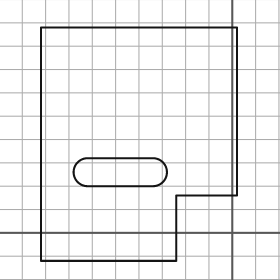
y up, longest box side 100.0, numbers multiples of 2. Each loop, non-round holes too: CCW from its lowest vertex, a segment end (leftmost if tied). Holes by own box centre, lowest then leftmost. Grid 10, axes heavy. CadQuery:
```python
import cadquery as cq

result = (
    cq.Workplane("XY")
    .moveTo(-82.0, -12.0)
    .lineTo(-24.0, -12.0)
    .lineTo(-24.0, 16.0)
    .lineTo(2.0, 16.0)
    .lineTo(2.0, 88.0)
    .lineTo(-82.0, 88.0)
    .close()
    .moveTo(-62.0, 20.0)
    .lineTo(-34.0, 20.0)
    .threePointArc((-28.0, 26.0), (-34.0, 32.0))
    .lineTo(-62.0, 32.0)
    .threePointArc((-68.0, 26.0), (-62.0, 20.0))
    .close()
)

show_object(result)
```